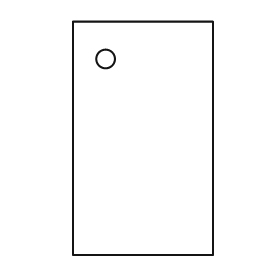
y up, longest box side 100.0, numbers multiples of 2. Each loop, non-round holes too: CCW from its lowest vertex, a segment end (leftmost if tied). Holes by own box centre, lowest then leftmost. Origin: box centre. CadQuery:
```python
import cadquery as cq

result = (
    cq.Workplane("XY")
    .moveTo(-30.0, -50.0)
    .lineTo(30.0, -50.0)
    .lineTo(30.0, 50.0)
    .lineTo(-30.0, 50.0)
    .close()
    .moveTo(-16.0, 34.0)
    .circle(4.0)
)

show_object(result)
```